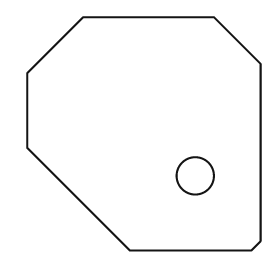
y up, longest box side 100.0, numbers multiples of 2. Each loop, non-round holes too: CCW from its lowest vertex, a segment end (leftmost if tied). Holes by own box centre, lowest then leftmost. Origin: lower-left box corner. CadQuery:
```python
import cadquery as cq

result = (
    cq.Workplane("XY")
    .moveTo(44.0, 0.0)
    .lineTo(96.0, 0.0)
    .lineTo(100.0, 4.0)
    .lineTo(100.0, 80.0)
    .lineTo(80.0, 100.0)
    .lineTo(24.0, 100.0)
    .lineTo(0.0, 76.0)
    .lineTo(0.0, 44.0)
    .close()
    .moveTo(72.0, 32.0)
    .circle(8.0)
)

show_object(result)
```